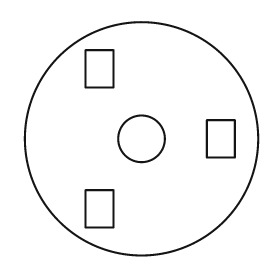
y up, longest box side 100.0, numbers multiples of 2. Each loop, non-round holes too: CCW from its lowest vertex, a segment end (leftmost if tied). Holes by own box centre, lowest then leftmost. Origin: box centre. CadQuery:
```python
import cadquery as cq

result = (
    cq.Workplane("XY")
    .moveTo(0.0, 0.0)
    .circle(50.0)
    .moveTo(-24.0, -38.0)
    .lineTo(-12.0, -38.0)
    .lineTo(-12.0, -22.0)
    .lineTo(-24.0, -22.0)
    .close()
    .moveTo(0.0, 0.0)
    .circle(10.0)
    .moveTo(28.0, -8.0)
    .lineTo(40.0, -8.0)
    .lineTo(40.0, 8.0)
    .lineTo(28.0, 8.0)
    .close()
    .moveTo(-24.0, 22.0)
    .lineTo(-12.0, 22.0)
    .lineTo(-12.0, 38.0)
    .lineTo(-24.0, 38.0)
    .close()
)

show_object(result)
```